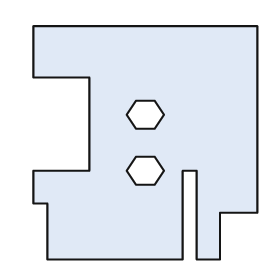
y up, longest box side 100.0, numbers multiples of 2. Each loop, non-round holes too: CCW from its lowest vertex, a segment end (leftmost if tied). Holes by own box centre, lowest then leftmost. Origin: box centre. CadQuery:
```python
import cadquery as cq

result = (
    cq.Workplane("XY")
    .moveTo(-42.0, -50.0)
    .lineTo(16.0, -50.0)
    .lineTo(16.0, -12.0)
    .lineTo(22.0, -12.0)
    .lineTo(22.0, -50.0)
    .lineTo(32.0, -50.0)
    .lineTo(32.0, -30.0)
    .lineTo(48.0, -30.0)
    .lineTo(48.0, 50.0)
    .lineTo(-48.0, 50.0)
    .lineTo(-48.0, 28.0)
    .lineTo(-24.0, 28.0)
    .lineTo(-24.0, -12.0)
    .lineTo(-48.0, -12.0)
    .lineTo(-48.0, -26.0)
    .lineTo(-42.0, -26.0)
    .close()
    .moveTo(-4.0, -18.0)
    .lineTo(4.0, -18.0)
    .lineTo(8.0, -12.0)
    .lineTo(4.0, -6.0)
    .lineTo(-4.0, -6.0)
    .lineTo(-8.0, -12.0)
    .close()
    .moveTo(-4.0, 6.0)
    .lineTo(4.0, 6.0)
    .lineTo(8.0, 12.0)
    .lineTo(4.0, 18.0)
    .lineTo(-4.0, 18.0)
    .lineTo(-8.0, 12.0)
    .close()
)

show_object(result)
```